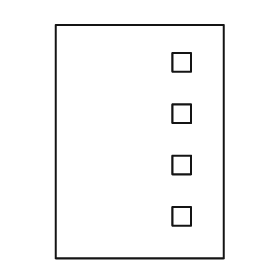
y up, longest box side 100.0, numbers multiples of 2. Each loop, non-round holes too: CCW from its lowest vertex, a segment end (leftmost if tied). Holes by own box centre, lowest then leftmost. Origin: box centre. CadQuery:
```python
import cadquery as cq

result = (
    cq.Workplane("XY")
    .moveTo(-36.0, -50.0)
    .lineTo(36.0, -50.0)
    .lineTo(36.0, 50.0)
    .lineTo(-36.0, 50.0)
    .close()
    .moveTo(14.0, -36.0)
    .lineTo(22.0, -36.0)
    .lineTo(22.0, -28.0)
    .lineTo(14.0, -28.0)
    .close()
    .moveTo(14.0, -14.0)
    .lineTo(22.0, -14.0)
    .lineTo(22.0, -6.0)
    .lineTo(14.0, -6.0)
    .close()
    .moveTo(14.0, 8.0)
    .lineTo(22.0, 8.0)
    .lineTo(22.0, 16.0)
    .lineTo(14.0, 16.0)
    .close()
    .moveTo(14.0, 30.0)
    .lineTo(22.0, 30.0)
    .lineTo(22.0, 38.0)
    .lineTo(14.0, 38.0)
    .close()
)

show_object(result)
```